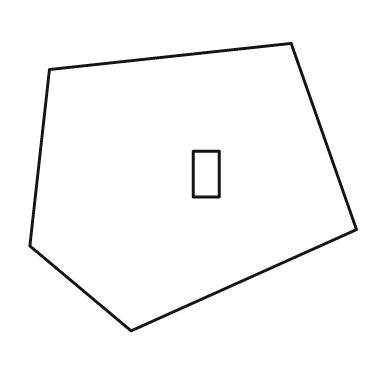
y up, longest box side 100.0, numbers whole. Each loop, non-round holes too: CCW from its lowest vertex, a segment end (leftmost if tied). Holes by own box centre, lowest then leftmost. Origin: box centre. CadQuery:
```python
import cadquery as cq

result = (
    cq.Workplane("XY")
    .moveTo(-19.0, -44.0)
    .lineTo(50.0, -13.0)
    .lineTo(30.0, 44.0)
    .lineTo(-44.0, 36.0)
    .lineTo(-50.0, -18.0)
    .close()
    .moveTo(0.0, -3.0)
    .lineTo(8.0, -3.0)
    .lineTo(8.0, 11.0)
    .lineTo(0.0, 11.0)
    .close()
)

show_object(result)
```